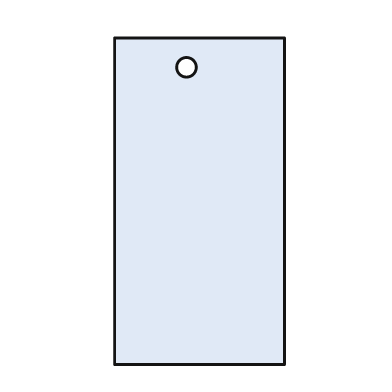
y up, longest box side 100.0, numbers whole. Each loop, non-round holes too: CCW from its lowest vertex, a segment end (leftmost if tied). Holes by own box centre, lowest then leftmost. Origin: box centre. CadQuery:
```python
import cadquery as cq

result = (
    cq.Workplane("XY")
    .moveTo(-26.0, -50.0)
    .lineTo(26.0, -50.0)
    .lineTo(26.0, 50.0)
    .lineTo(-26.0, 50.0)
    .close()
    .moveTo(-4.0, 41.0)
    .circle(3.0)
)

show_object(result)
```